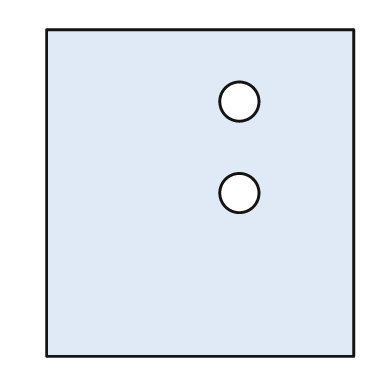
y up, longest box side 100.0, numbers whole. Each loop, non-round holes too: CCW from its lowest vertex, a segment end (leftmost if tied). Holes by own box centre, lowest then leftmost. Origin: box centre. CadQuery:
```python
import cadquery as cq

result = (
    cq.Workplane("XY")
    .moveTo(-47.0, -50.0)
    .lineTo(47.0, -50.0)
    .lineTo(47.0, 50.0)
    .lineTo(-47.0, 50.0)
    .close()
    .moveTo(12.0, 0.0)
    .circle(6.0)
    .moveTo(12.0, 28.0)
    .circle(6.0)
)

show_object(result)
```